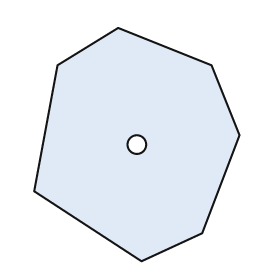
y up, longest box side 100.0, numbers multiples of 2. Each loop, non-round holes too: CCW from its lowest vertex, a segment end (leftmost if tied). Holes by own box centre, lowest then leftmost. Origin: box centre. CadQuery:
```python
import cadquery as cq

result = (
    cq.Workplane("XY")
    .moveTo(2.0, -50.0)
    .lineTo(28.0, -38.0)
    .lineTo(44.0, 4.0)
    .lineTo(32.0, 34.0)
    .lineTo(-8.0, 50.0)
    .lineTo(-34.0, 34.0)
    .lineTo(-44.0, -20.0)
    .close()
    .moveTo(0.0, 0.0)
    .circle(4.0)
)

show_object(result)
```